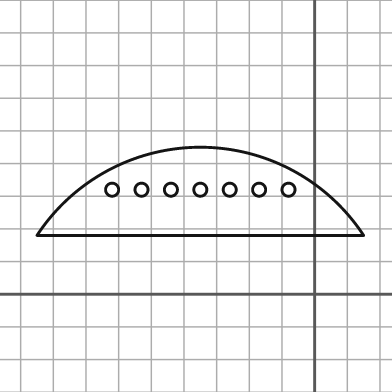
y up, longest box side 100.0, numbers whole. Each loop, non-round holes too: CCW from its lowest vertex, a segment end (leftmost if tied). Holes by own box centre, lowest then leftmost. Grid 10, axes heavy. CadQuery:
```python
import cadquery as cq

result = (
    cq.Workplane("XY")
    .moveTo(-85.0, 18.0)
    .lineTo(15.0, 18.0)
    .threePointArc((-35.0, 45.0), (-85.0, 18.0))
    .close()
    .moveTo(-62.0, 32.0)
    .circle(2.0)
    .moveTo(-53.0, 32.0)
    .circle(2.0)
    .moveTo(-44.0, 32.0)
    .circle(2.0)
    .moveTo(-35.0, 32.0)
    .circle(2.0)
    .moveTo(-26.0, 32.0)
    .circle(2.0)
    .moveTo(-17.0, 32.0)
    .circle(2.0)
    .moveTo(-8.0, 32.0)
    .circle(2.0)
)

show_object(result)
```